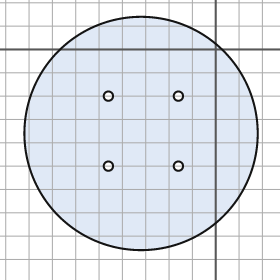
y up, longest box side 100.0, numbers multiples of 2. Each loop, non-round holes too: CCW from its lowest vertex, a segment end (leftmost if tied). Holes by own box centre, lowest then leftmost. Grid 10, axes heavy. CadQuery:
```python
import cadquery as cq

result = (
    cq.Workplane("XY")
    .moveTo(-32.0, -36.0)
    .circle(50.0)
    .moveTo(-46.0, -50.0)
    .circle(2.0)
    .moveTo(-16.0, -50.0)
    .circle(2.0)
    .moveTo(-46.0, -20.0)
    .circle(2.0)
    .moveTo(-16.0, -20.0)
    .circle(2.0)
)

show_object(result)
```